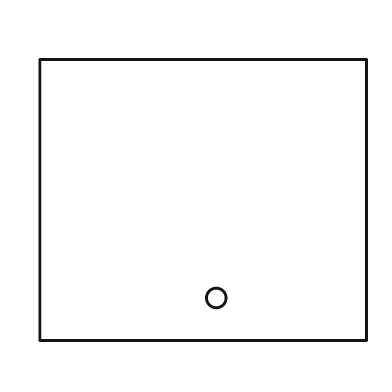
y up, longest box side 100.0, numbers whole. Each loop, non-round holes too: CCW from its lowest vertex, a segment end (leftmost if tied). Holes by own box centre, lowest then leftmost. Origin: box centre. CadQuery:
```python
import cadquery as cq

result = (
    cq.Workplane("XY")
    .moveTo(-50.0, -43.0)
    .lineTo(50.0, -43.0)
    .lineTo(50.0, 43.0)
    .lineTo(-50.0, 43.0)
    .close()
    .moveTo(4.0, -30.0)
    .circle(3.0)
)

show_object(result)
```